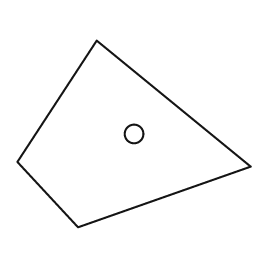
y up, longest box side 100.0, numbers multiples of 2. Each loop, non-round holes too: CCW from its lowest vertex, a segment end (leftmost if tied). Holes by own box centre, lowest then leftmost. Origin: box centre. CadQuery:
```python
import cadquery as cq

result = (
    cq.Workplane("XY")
    .moveTo(-24.0, -40.0)
    .lineTo(50.0, -14.0)
    .lineTo(-16.0, 40.0)
    .lineTo(-50.0, -12.0)
    .close()
    .moveTo(0.0, 0.0)
    .circle(4.0)
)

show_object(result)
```